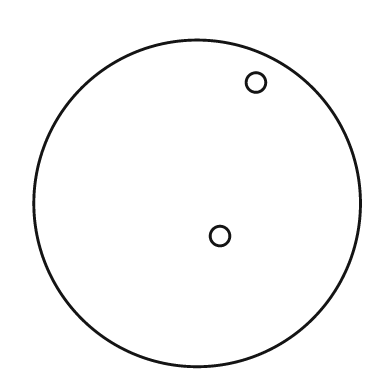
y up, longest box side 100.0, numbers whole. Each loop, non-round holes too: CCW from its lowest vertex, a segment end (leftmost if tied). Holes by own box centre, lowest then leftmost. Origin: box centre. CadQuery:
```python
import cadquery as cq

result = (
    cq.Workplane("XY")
    .moveTo(0.0, 0.0)
    .circle(50.0)
    .moveTo(7.0, -10.0)
    .circle(3.0)
    .moveTo(18.0, 37.0)
    .circle(3.0)
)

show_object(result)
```